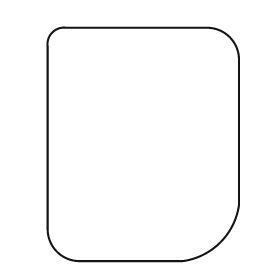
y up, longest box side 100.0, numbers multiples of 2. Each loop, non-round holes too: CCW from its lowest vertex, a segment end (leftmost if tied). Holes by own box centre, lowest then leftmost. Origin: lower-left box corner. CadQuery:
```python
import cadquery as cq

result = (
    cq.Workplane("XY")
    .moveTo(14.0, 0.0)
    .lineTo(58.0, 0.0)
    .threePointArc((74.0, 8.0), (82.0, 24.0))
    .lineTo(82.0, 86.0)
    .threePointArc((78.0, 96.0), (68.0, 100.0))
    .lineTo(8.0, 100.0)
    .threePointArc((2.0, 98.0), (0.0, 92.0))
    .lineTo(0.0, 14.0)
    .threePointArc((4.0, 4.0), (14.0, 0.0))
    .close()
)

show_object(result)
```